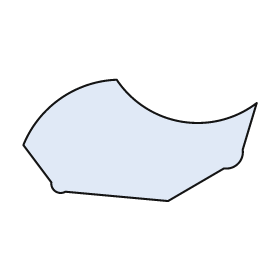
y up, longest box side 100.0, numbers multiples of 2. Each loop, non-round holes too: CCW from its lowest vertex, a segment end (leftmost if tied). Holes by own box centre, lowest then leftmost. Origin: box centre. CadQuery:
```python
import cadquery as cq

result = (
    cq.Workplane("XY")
    .moveTo(12.0, -26.0)
    .lineTo(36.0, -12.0)
    .threePointArc((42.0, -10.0), (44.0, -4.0))
    .lineTo(50.0, 16.0)
    .threePointArc((18.0, 8.0), (-10.0, 26.0))
    .threePointArc((-34.0, 18.0), (-50.0, -2.0))
    .lineTo(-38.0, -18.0)
    .threePointArc((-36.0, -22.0), (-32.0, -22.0))
    .close()
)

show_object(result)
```